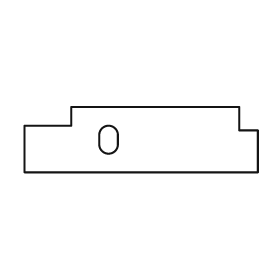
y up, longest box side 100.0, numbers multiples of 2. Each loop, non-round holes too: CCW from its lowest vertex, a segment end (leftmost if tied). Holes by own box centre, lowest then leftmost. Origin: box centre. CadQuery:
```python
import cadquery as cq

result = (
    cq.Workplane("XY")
    .moveTo(-50.0, -14.0)
    .lineTo(50.0, -14.0)
    .lineTo(50.0, 4.0)
    .lineTo(42.0, 4.0)
    .lineTo(42.0, 14.0)
    .lineTo(-30.0, 14.0)
    .lineTo(-30.0, 6.0)
    .lineTo(-50.0, 6.0)
    .close()
    .moveTo(-18.0, -2.0)
    .threePointArc((-14.0, -6.0), (-10.0, -2.0))
    .lineTo(-10.0, 2.0)
    .threePointArc((-14.0, 6.0), (-18.0, 2.0))
    .close()
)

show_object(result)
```